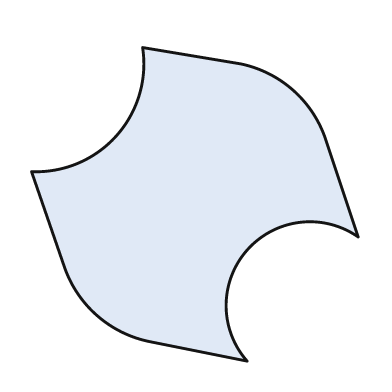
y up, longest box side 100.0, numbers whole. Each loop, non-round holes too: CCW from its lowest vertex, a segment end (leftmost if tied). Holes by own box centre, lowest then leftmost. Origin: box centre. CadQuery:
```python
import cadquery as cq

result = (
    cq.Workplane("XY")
    .moveTo(16.0, -48.0)
    .threePointArc((16.0, -14.0), (50.0, -10.0))
    .lineTo(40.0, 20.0)
    .threePointArc((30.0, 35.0), (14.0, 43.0))
    .lineTo(-16.0, 48.0)
    .threePointArc((-24.0, 21.0), (-50.0, 10.0))
    .lineTo(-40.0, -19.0)
    .threePointArc((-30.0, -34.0), (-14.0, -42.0))
    .close()
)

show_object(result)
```